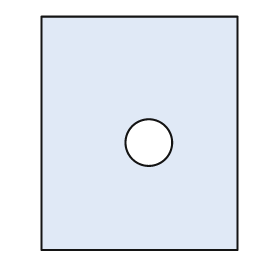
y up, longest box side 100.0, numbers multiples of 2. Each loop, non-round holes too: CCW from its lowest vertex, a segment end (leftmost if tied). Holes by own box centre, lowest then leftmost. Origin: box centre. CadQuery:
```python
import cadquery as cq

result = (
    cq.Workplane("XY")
    .moveTo(-42.0, -50.0)
    .lineTo(42.0, -50.0)
    .lineTo(42.0, 50.0)
    .lineTo(-42.0, 50.0)
    .close()
    .moveTo(4.0, -4.0)
    .circle(10.0)
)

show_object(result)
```